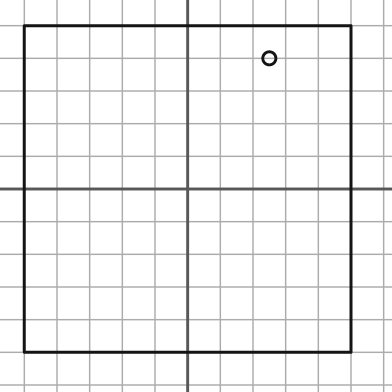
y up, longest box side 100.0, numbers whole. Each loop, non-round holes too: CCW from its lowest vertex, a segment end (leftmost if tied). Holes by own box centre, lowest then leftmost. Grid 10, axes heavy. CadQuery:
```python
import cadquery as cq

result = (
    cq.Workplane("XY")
    .moveTo(-50.0, -50.0)
    .lineTo(50.0, -50.0)
    .lineTo(50.0, 50.0)
    .lineTo(-50.0, 50.0)
    .close()
    .moveTo(25.0, 40.0)
    .circle(2.0)
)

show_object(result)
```